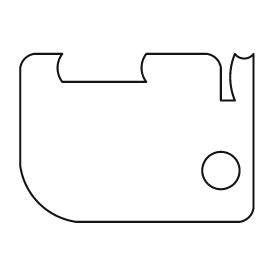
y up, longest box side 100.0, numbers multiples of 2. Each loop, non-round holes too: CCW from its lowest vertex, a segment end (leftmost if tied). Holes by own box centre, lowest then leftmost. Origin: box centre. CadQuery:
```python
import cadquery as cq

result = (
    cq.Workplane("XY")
    .moveTo(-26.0, -36.0)
    .lineTo(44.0, -36.0)
    .threePointArc((48.0, -34.0), (50.0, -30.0))
    .lineTo(50.0, 36.0)
    .threePointArc((46.0, 34.0), (42.0, 36.0))
    .threePointArc((40.0, 26.0), (42.0, 16.0))
    .lineTo(36.0, 16.0)
    .lineTo(36.0, 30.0)
    .threePointArc((34.0, 34.0), (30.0, 36.0))
    .lineTo(4.0, 36.0)
    .threePointArc((2.0, 30.0), (4.0, 24.0))
    .lineTo(-32.0, 24.0)
    .threePointArc((-34.0, 30.0), (-32.0, 36.0))
    .lineTo(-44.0, 36.0)
    .threePointArc((-48.0, 34.0), (-50.0, 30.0))
    .lineTo(-50.0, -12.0)
    .threePointArc((-42.0, -28.0), (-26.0, -36.0))
    .close()
    .moveTo(36.0, -14.0)
    .circle(8.0)
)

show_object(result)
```